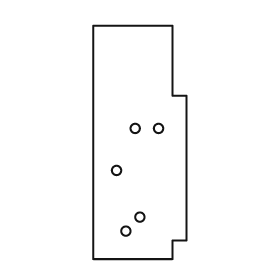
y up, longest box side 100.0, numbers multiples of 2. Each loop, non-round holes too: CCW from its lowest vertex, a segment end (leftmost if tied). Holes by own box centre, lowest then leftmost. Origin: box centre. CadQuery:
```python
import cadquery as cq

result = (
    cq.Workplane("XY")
    .moveTo(-20.0, -50.0)
    .lineTo(14.0, -50.0)
    .lineTo(14.0, -42.0)
    .lineTo(20.0, -42.0)
    .lineTo(20.0, 20.0)
    .lineTo(14.0, 20.0)
    .lineTo(14.0, 50.0)
    .lineTo(-20.0, 50.0)
    .close()
    .moveTo(-6.0, -38.0)
    .circle(2.0)
    .moveTo(0.0, -32.0)
    .circle(2.0)
    .moveTo(-10.0, -12.0)
    .circle(2.0)
    .moveTo(-2.0, 6.0)
    .circle(2.0)
    .moveTo(8.0, 6.0)
    .circle(2.0)
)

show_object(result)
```